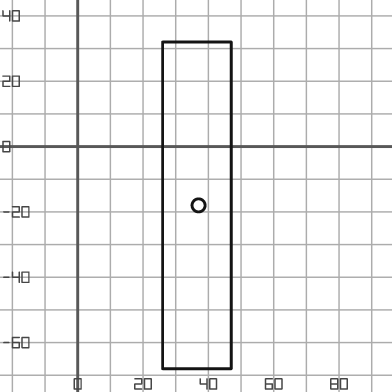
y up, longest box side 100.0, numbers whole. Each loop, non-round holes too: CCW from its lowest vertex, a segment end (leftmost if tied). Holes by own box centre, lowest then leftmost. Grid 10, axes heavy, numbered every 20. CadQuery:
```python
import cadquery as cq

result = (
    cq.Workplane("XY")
    .moveTo(26.0, -68.0)
    .lineTo(47.0, -68.0)
    .lineTo(47.0, 32.0)
    .lineTo(26.0, 32.0)
    .close()
    .moveTo(37.0, -18.0)
    .circle(2.0)
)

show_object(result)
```